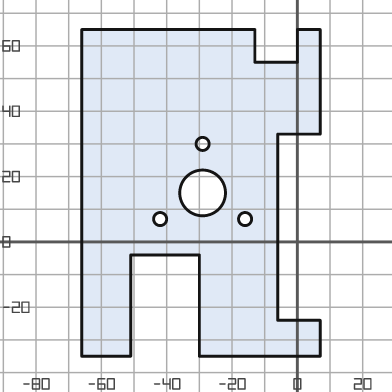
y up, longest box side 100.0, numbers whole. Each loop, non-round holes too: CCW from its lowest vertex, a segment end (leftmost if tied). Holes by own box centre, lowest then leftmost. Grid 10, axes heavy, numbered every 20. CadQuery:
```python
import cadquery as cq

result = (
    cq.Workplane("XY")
    .moveTo(-66.0, -35.0)
    .lineTo(-51.0, -35.0)
    .lineTo(-51.0, -4.0)
    .lineTo(-30.0, -4.0)
    .lineTo(-30.0, -35.0)
    .lineTo(7.0, -35.0)
    .lineTo(7.0, -24.0)
    .lineTo(-6.0, -24.0)
    .lineTo(-6.0, 33.0)
    .lineTo(7.0, 33.0)
    .lineTo(7.0, 65.0)
    .lineTo(0.0, 65.0)
    .lineTo(0.0, 55.0)
    .lineTo(-13.0, 55.0)
    .lineTo(-13.0, 65.0)
    .lineTo(-66.0, 65.0)
    .close()
    .moveTo(-42.0, 7.0)
    .circle(2.0)
    .moveTo(-16.0, 7.0)
    .circle(2.0)
    .moveTo(-29.0, 15.0)
    .circle(7.0)
    .moveTo(-29.0, 30.0)
    .circle(2.0)
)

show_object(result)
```